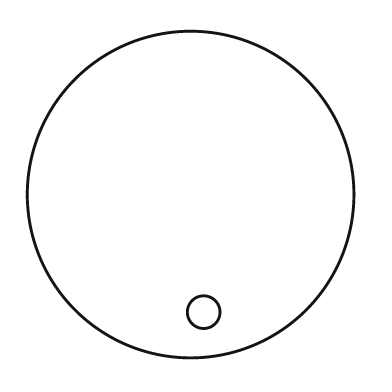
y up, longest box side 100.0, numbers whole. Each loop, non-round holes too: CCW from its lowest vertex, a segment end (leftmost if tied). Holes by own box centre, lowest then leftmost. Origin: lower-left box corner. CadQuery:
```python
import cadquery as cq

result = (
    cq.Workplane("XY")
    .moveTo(50.0, 50.0)
    .circle(50.0)
    .moveTo(54.0, 14.0)
    .circle(5.0)
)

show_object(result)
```